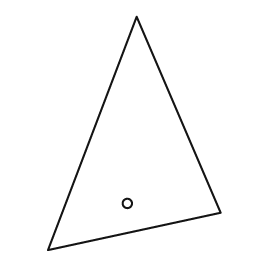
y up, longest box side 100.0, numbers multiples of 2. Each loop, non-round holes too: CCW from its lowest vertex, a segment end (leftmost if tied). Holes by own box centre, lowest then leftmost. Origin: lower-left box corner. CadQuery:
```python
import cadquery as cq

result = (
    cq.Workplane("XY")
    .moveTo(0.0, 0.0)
    .lineTo(74.0, 16.0)
    .lineTo(38.0, 100.0)
    .close()
    .moveTo(34.0, 20.0)
    .circle(2.0)
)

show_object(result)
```